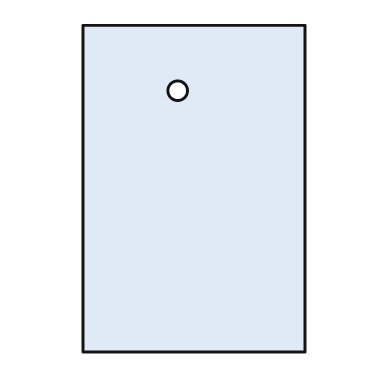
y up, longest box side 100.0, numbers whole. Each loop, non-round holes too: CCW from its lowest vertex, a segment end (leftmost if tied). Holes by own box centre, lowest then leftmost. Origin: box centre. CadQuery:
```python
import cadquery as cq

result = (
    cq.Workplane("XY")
    .moveTo(-34.0, -50.0)
    .lineTo(34.0, -50.0)
    .lineTo(34.0, 50.0)
    .lineTo(-34.0, 50.0)
    .close()
    .moveTo(-5.0, 30.0)
    .circle(3.0)
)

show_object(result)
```